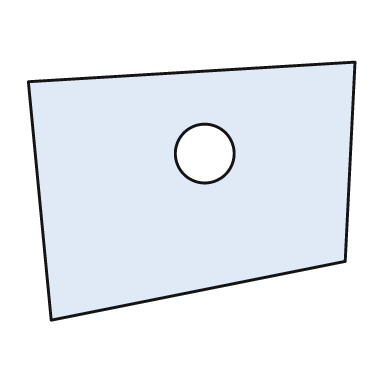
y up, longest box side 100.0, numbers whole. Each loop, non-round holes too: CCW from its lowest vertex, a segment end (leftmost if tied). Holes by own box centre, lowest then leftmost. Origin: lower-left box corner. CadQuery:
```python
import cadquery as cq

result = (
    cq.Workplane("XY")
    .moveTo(7.0, 0.0)
    .lineTo(97.0, 18.0)
    .lineTo(100.0, 79.0)
    .lineTo(0.0, 73.0)
    .close()
    .moveTo(54.0, 51.0)
    .circle(9.0)
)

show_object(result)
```